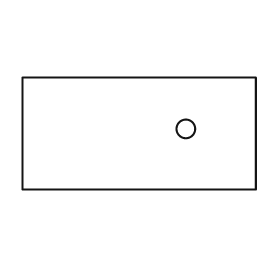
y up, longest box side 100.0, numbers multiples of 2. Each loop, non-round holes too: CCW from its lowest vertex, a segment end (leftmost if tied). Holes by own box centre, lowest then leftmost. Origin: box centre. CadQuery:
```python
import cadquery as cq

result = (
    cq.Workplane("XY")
    .moveTo(-50.0, -24.0)
    .lineTo(50.0, -24.0)
    .lineTo(50.0, 24.0)
    .lineTo(-50.0, 24.0)
    .close()
    .moveTo(20.0, 2.0)
    .circle(4.0)
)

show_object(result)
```